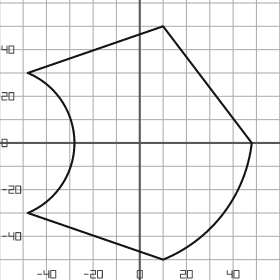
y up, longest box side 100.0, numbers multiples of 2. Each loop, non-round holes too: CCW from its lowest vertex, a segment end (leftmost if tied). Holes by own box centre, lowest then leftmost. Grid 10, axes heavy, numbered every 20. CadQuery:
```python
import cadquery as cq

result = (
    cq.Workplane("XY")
    .moveTo(10.0, -50.0)
    .threePointArc((36.0, -30.0), (48.0, 0.0))
    .lineTo(10.0, 50.0)
    .lineTo(-48.0, 30.0)
    .threePointArc((-28.0, 0.0), (-48.0, -30.0))
    .close()
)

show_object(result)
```